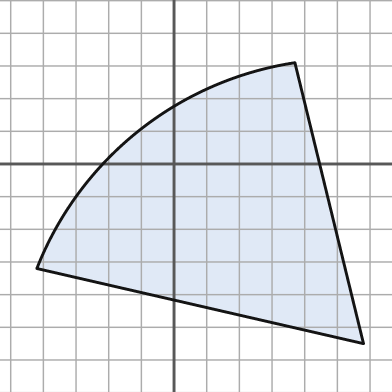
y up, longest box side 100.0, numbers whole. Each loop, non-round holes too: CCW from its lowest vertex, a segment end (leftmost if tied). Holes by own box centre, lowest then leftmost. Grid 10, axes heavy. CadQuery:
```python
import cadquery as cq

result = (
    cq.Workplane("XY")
    .moveTo(58.0, -55.0)
    .lineTo(37.0, 31.0)
    .threePointArc((-11.0, 10.0), (-42.0, -32.0))
    .close()
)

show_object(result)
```